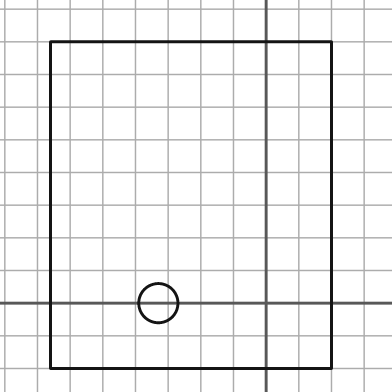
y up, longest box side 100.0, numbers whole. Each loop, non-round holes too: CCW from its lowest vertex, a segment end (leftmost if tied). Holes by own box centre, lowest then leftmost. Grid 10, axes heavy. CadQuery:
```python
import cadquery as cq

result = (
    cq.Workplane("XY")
    .moveTo(-66.0, -20.0)
    .lineTo(20.0, -20.0)
    .lineTo(20.0, 80.0)
    .lineTo(-66.0, 80.0)
    .close()
    .moveTo(-33.0, 0.0)
    .circle(6.0)
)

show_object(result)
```